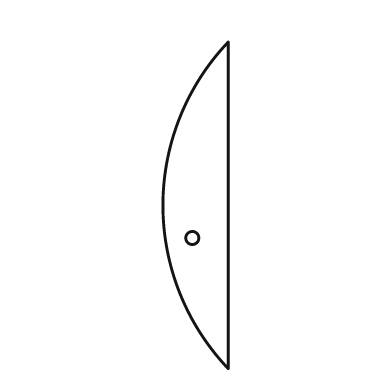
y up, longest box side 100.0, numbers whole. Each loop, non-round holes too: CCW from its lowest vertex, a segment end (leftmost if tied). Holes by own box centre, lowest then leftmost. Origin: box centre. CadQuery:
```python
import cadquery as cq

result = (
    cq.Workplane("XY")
    .moveTo(10.0, -50.0)
    .lineTo(10.0, 50.0)
    .threePointArc((-10.0, 0.0), (10.0, -50.0))
    .close()
    .moveTo(-1.0, -10.0)
    .circle(2.0)
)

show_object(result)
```